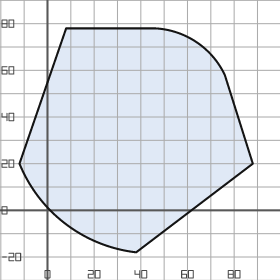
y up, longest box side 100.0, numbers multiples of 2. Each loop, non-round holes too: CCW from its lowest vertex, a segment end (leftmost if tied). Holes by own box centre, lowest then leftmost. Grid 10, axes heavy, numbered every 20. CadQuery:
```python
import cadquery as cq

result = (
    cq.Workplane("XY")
    .moveTo(38.0, -18.0)
    .lineTo(88.0, 20.0)
    .lineTo(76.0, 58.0)
    .threePointArc((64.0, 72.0), (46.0, 78.0))
    .lineTo(8.0, 78.0)
    .lineTo(-12.0, 20.0)
    .threePointArc((8.0, -6.0), (38.0, -18.0))
    .close()
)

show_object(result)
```